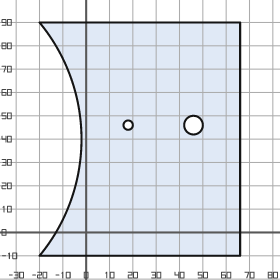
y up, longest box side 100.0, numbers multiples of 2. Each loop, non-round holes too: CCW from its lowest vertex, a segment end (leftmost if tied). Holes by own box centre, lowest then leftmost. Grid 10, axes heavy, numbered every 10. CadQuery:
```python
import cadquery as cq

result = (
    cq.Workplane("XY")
    .moveTo(-20.0, -10.0)
    .lineTo(66.0, -10.0)
    .lineTo(66.0, 90.0)
    .lineTo(-20.0, 90.0)
    .threePointArc((-2.0, 40.0), (-20.0, -10.0))
    .close()
    .moveTo(18.0, 46.0)
    .circle(2.0)
    .moveTo(46.0, 46.0)
    .circle(4.0)
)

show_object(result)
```